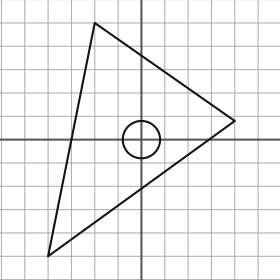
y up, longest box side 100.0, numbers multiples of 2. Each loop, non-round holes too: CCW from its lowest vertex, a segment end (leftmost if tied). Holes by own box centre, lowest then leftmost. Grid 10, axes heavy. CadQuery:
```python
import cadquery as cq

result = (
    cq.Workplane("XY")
    .moveTo(-40.0, -50.0)
    .lineTo(40.0, 8.0)
    .lineTo(-20.0, 50.0)
    .close()
    .moveTo(0.0, 0.0)
    .circle(8.0)
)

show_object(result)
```